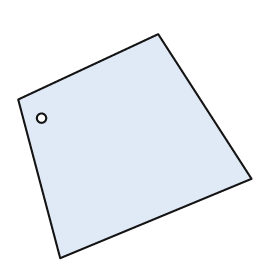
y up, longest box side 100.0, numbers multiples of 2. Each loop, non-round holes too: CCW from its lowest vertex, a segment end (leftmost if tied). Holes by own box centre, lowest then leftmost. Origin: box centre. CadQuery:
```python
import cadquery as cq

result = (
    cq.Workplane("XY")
    .moveTo(-32.0, -48.0)
    .lineTo(50.0, -14.0)
    .lineTo(10.0, 48.0)
    .lineTo(-50.0, 20.0)
    .close()
    .moveTo(-40.0, 12.0)
    .circle(2.0)
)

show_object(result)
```